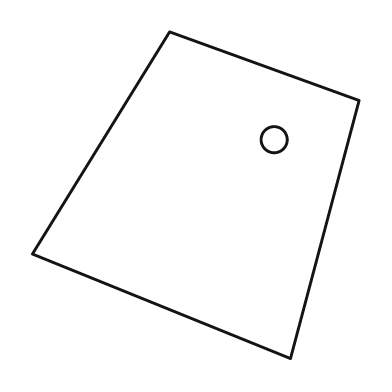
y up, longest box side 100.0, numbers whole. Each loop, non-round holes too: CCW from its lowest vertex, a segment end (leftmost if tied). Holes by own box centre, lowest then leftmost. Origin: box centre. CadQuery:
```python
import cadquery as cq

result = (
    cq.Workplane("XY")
    .moveTo(29.0, -50.0)
    .lineTo(50.0, 29.0)
    .lineTo(-8.0, 50.0)
    .lineTo(-50.0, -18.0)
    .close()
    .moveTo(24.0, 17.0)
    .circle(4.0)
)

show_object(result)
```